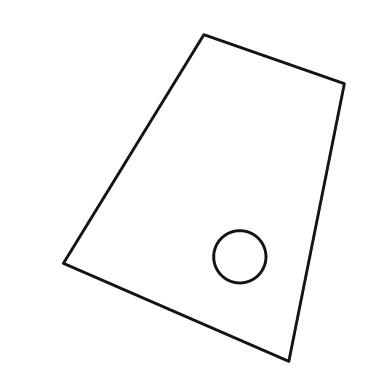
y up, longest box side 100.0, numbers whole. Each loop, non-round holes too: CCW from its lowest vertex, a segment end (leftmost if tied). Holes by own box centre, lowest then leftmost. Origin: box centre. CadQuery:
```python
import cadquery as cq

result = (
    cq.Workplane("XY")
    .moveTo(26.0, -50.0)
    .lineTo(43.0, 35.0)
    .lineTo(0.0, 50.0)
    .lineTo(-43.0, -20.0)
    .close()
    .moveTo(11.0, -18.0)
    .circle(8.0)
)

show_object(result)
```